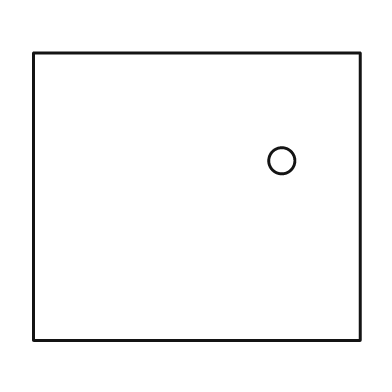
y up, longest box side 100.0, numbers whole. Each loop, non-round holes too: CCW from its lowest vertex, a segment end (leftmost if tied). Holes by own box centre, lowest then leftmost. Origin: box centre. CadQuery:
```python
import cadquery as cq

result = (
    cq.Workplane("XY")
    .moveTo(-50.0, -44.0)
    .lineTo(50.0, -44.0)
    .lineTo(50.0, 44.0)
    .lineTo(-50.0, 44.0)
    .close()
    .moveTo(26.0, 11.0)
    .circle(4.0)
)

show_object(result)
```